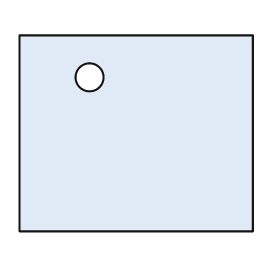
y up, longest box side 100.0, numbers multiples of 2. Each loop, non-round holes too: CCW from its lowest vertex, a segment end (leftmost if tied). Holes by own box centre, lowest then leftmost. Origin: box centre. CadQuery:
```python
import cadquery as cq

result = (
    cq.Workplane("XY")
    .moveTo(-50.0, -42.0)
    .lineTo(50.0, -42.0)
    .lineTo(50.0, 42.0)
    .lineTo(-50.0, 42.0)
    .close()
    .moveTo(-20.0, 24.0)
    .circle(6.0)
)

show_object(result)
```